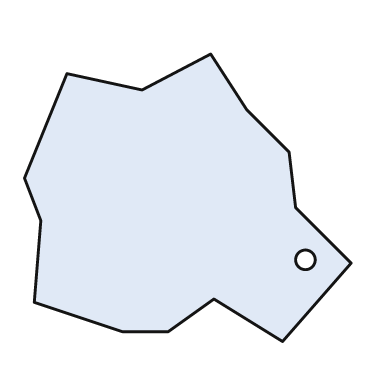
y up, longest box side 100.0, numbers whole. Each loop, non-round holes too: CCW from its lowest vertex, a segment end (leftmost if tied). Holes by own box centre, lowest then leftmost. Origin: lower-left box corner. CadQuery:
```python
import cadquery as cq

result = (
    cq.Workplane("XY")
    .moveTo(79.0, 0.0)
    .lineTo(100.0, 24.0)
    .lineTo(83.0, 41.0)
    .lineTo(81.0, 58.0)
    .lineTo(68.0, 71.0)
    .lineTo(57.0, 88.0)
    .lineTo(36.0, 77.0)
    .lineTo(13.0, 82.0)
    .lineTo(0.0, 50.0)
    .lineTo(5.0, 37.0)
    .lineTo(3.0, 12.0)
    .lineTo(30.0, 3.0)
    .lineTo(44.0, 3.0)
    .lineTo(58.0, 13.0)
    .close()
    .moveTo(86.0, 25.0)
    .circle(3.0)
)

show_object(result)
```